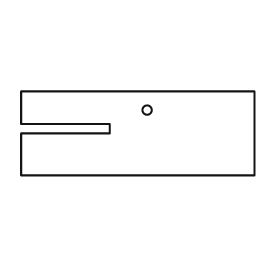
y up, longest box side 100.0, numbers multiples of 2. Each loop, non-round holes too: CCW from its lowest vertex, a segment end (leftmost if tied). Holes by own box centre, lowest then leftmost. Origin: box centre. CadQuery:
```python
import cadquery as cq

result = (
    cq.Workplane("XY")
    .moveTo(-50.0, -18.0)
    .lineTo(50.0, -18.0)
    .lineTo(50.0, 18.0)
    .lineTo(-50.0, 18.0)
    .lineTo(-50.0, 4.0)
    .lineTo(-12.0, 4.0)
    .lineTo(-12.0, 0.0)
    .lineTo(-50.0, 0.0)
    .close()
    .moveTo(4.0, 10.0)
    .circle(2.0)
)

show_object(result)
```